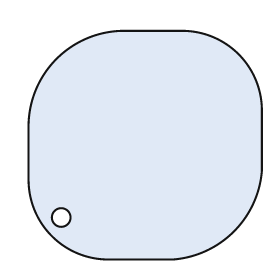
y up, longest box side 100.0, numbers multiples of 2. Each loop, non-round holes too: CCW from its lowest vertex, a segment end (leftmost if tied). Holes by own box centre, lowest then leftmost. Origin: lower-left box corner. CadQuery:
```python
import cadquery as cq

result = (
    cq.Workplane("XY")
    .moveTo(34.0, 0.0)
    .lineTo(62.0, 0.0)
    .threePointArc((88.0, 12.0), (100.0, 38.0))
    .lineTo(100.0, 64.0)
    .threePointArc((90.0, 88.0), (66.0, 98.0))
    .lineTo(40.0, 98.0)
    .threePointArc((12.0, 86.0), (0.0, 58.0))
    .lineTo(0.0, 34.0)
    .threePointArc((10.0, 10.0), (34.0, 0.0))
    .close()
    .moveTo(14.0, 18.0)
    .circle(4.0)
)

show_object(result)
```